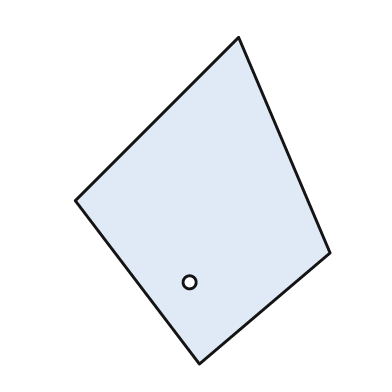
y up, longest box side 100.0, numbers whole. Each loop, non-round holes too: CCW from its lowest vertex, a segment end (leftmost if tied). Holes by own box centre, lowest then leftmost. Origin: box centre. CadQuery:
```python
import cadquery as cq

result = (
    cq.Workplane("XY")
    .moveTo(-1.0, -50.0)
    .lineTo(39.0, -16.0)
    .lineTo(11.0, 50.0)
    .lineTo(-39.0, 0.0)
    .close()
    .moveTo(-4.0, -25.0)
    .circle(2.0)
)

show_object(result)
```